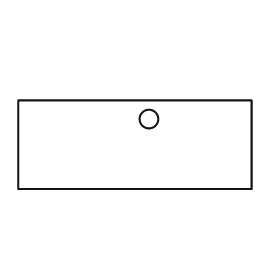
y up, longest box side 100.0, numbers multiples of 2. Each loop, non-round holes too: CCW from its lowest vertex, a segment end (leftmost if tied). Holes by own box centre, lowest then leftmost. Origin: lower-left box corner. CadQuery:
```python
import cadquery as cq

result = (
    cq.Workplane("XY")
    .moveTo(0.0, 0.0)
    .lineTo(100.0, 0.0)
    .lineTo(100.0, 38.0)
    .lineTo(0.0, 38.0)
    .close()
    .moveTo(56.0, 30.0)
    .circle(4.0)
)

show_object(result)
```